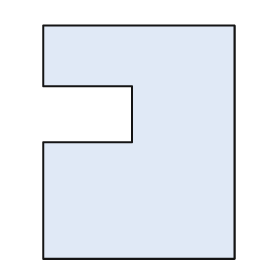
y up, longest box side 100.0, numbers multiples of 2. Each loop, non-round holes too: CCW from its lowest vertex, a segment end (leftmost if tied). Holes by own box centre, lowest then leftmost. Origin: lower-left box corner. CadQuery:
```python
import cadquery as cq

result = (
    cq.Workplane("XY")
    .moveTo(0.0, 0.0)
    .lineTo(82.0, 0.0)
    .lineTo(82.0, 100.0)
    .lineTo(0.0, 100.0)
    .lineTo(0.0, 74.0)
    .lineTo(38.0, 74.0)
    .lineTo(38.0, 50.0)
    .lineTo(0.0, 50.0)
    .close()
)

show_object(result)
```